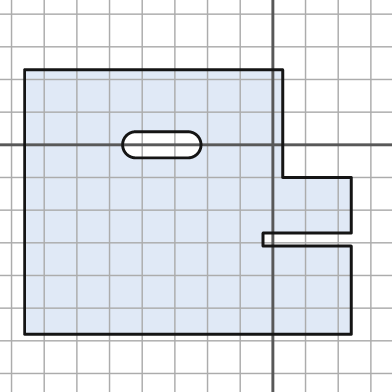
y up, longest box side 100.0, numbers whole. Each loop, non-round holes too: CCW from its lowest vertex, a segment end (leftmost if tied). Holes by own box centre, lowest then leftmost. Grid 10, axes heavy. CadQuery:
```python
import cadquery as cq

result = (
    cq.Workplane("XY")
    .moveTo(-76.0, -58.0)
    .lineTo(24.0, -58.0)
    .lineTo(24.0, -31.0)
    .lineTo(-3.0, -31.0)
    .lineTo(-3.0, -27.0)
    .lineTo(24.0, -27.0)
    .lineTo(24.0, -10.0)
    .lineTo(3.0, -10.0)
    .lineTo(3.0, 23.0)
    .lineTo(-76.0, 23.0)
    .close()
    .moveTo(-42.0, -4.0)
    .lineTo(-26.0, -4.0)
    .threePointArc((-22.0, 0.0), (-26.0, 4.0))
    .lineTo(-42.0, 4.0)
    .threePointArc((-46.0, 0.0), (-42.0, -4.0))
    .close()
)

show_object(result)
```